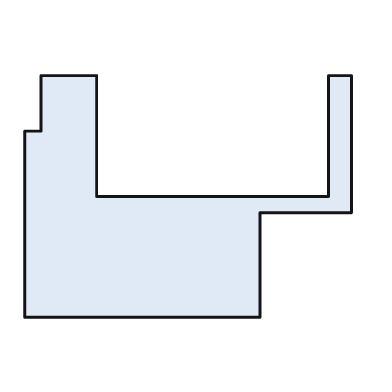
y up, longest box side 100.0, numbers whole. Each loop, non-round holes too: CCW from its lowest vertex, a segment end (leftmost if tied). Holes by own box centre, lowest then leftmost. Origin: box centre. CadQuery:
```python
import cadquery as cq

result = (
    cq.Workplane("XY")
    .moveTo(-50.0, -37.0)
    .lineTo(22.0, -37.0)
    .lineTo(22.0, -5.0)
    .lineTo(50.0, -5.0)
    .lineTo(50.0, 37.0)
    .lineTo(43.0, 37.0)
    .lineTo(43.0, 0.0)
    .lineTo(-28.0, 0.0)
    .lineTo(-28.0, 37.0)
    .lineTo(-45.0, 37.0)
    .lineTo(-45.0, 20.0)
    .lineTo(-50.0, 20.0)
    .close()
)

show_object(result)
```